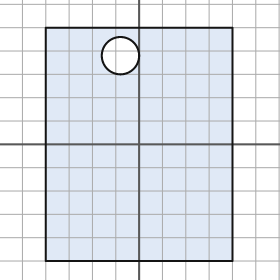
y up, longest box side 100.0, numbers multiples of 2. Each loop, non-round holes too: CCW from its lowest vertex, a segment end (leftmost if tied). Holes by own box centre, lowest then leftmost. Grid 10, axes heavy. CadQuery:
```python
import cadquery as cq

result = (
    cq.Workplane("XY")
    .moveTo(-40.0, -50.0)
    .lineTo(40.0, -50.0)
    .lineTo(40.0, 50.0)
    .lineTo(-40.0, 50.0)
    .close()
    .moveTo(-8.0, 38.0)
    .circle(8.0)
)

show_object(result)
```